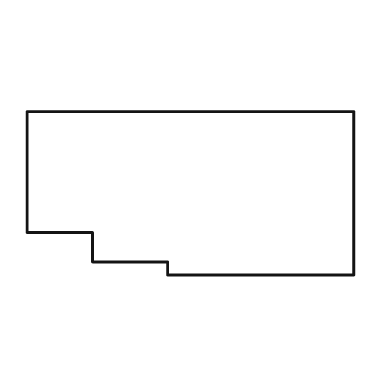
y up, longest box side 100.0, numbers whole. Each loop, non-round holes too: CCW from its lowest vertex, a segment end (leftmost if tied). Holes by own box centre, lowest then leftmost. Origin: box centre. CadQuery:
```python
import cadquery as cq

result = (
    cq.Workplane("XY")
    .moveTo(-7.0, -25.0)
    .lineTo(50.0, -25.0)
    .lineTo(50.0, 25.0)
    .lineTo(-50.0, 25.0)
    .lineTo(-50.0, -12.0)
    .lineTo(-30.0, -12.0)
    .lineTo(-30.0, -21.0)
    .lineTo(-7.0, -21.0)
    .close()
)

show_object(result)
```